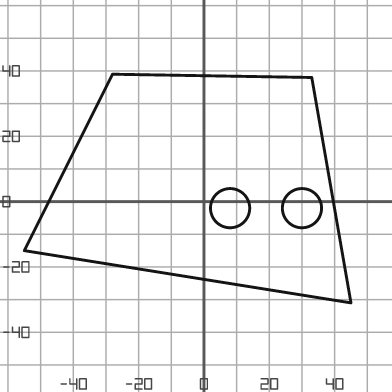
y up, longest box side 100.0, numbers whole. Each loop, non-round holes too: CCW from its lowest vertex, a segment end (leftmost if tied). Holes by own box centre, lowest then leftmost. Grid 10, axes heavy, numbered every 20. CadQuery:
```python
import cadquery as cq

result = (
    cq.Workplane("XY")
    .moveTo(45.0, -31.0)
    .lineTo(33.0, 38.0)
    .lineTo(-28.0, 39.0)
    .lineTo(-55.0, -15.0)
    .close()
    .moveTo(8.0, -2.0)
    .circle(6.0)
    .moveTo(30.0, -2.0)
    .circle(6.0)
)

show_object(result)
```